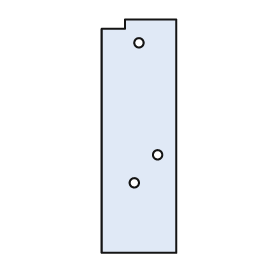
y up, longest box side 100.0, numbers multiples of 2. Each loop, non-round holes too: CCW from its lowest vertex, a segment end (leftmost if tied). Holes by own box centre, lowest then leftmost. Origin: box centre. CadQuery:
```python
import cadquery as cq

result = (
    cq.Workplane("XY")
    .moveTo(-16.0, -50.0)
    .lineTo(16.0, -50.0)
    .lineTo(16.0, 50.0)
    .lineTo(-6.0, 50.0)
    .lineTo(-6.0, 46.0)
    .lineTo(-16.0, 46.0)
    .close()
    .moveTo(-2.0, -20.0)
    .circle(2.0)
    .moveTo(8.0, -8.0)
    .circle(2.0)
    .moveTo(0.0, 40.0)
    .circle(2.0)
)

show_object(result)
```